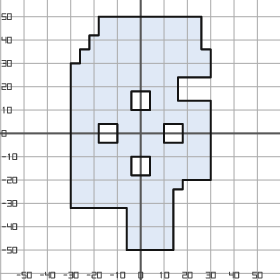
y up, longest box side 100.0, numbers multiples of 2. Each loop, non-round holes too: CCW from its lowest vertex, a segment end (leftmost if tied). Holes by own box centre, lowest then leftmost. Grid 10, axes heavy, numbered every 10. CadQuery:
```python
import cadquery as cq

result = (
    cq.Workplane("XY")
    .moveTo(-6.0, -50.0)
    .lineTo(14.0, -50.0)
    .lineTo(14.0, -24.0)
    .lineTo(18.0, -24.0)
    .lineTo(18.0, -20.0)
    .lineTo(30.0, -20.0)
    .lineTo(30.0, 14.0)
    .lineTo(16.0, 14.0)
    .lineTo(16.0, 24.0)
    .lineTo(30.0, 24.0)
    .lineTo(30.0, 36.0)
    .lineTo(26.0, 36.0)
    .lineTo(26.0, 50.0)
    .lineTo(-18.0, 50.0)
    .lineTo(-18.0, 42.0)
    .lineTo(-22.0, 42.0)
    .lineTo(-22.0, 36.0)
    .lineTo(-26.0, 36.0)
    .lineTo(-26.0, 30.0)
    .lineTo(-30.0, 30.0)
    .lineTo(-30.0, -32.0)
    .lineTo(-6.0, -32.0)
    .close()
    .moveTo(-4.0, -18.0)
    .lineTo(4.0, -18.0)
    .lineTo(4.0, -10.0)
    .lineTo(-4.0, -10.0)
    .close()
    .moveTo(-18.0, -4.0)
    .lineTo(-10.0, -4.0)
    .lineTo(-10.0, 4.0)
    .lineTo(-18.0, 4.0)
    .close()
    .moveTo(10.0, -4.0)
    .lineTo(18.0, -4.0)
    .lineTo(18.0, 4.0)
    .lineTo(10.0, 4.0)
    .close()
    .moveTo(-4.0, 10.0)
    .lineTo(4.0, 10.0)
    .lineTo(4.0, 18.0)
    .lineTo(-4.0, 18.0)
    .close()
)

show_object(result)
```